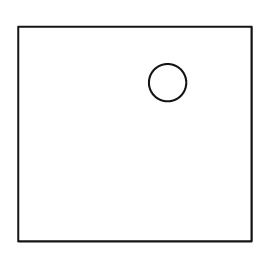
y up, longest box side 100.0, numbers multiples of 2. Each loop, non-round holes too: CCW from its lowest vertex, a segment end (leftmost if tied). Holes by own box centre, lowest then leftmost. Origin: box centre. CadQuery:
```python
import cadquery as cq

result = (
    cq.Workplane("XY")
    .moveTo(-50.0, -46.0)
    .lineTo(50.0, -46.0)
    .lineTo(50.0, 46.0)
    .lineTo(-50.0, 46.0)
    .close()
    .moveTo(14.0, 22.0)
    .circle(8.0)
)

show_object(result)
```